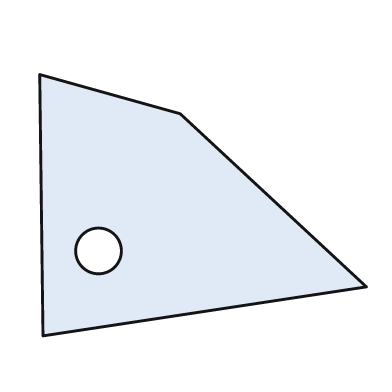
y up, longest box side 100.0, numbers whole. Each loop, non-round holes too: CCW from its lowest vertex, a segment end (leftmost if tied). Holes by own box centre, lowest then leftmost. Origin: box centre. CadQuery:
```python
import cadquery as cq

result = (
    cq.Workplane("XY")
    .moveTo(-49.0, -40.0)
    .lineTo(50.0, -25.0)
    .lineTo(-7.0, 28.0)
    .lineTo(-50.0, 40.0)
    .close()
    .moveTo(-32.0, -14.0)
    .circle(7.0)
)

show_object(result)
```